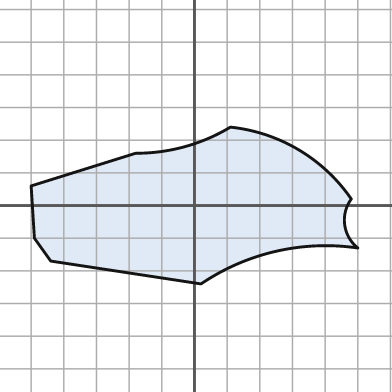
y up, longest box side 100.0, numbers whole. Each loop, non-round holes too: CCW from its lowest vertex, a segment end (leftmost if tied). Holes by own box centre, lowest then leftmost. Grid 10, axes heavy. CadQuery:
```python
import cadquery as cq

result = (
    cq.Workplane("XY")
    .moveTo(2.0, -24.0)
    .threePointArc((25.0, -14.0), (50.0, -13.0))
    .threePointArc((46.0, -6.0), (48.0, 2.0))
    .threePointArc((32.0, 17.0), (11.0, 24.0))
    .threePointArc((-3.0, 18.0), (-18.0, 16.0))
    .lineTo(-50.0, 6.0)
    .lineTo(-49.0, -10.0)
    .lineTo(-44.0, -17.0)
    .close()
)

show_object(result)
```